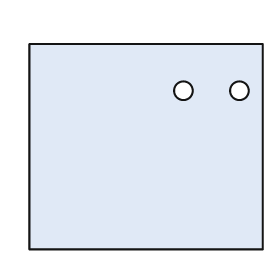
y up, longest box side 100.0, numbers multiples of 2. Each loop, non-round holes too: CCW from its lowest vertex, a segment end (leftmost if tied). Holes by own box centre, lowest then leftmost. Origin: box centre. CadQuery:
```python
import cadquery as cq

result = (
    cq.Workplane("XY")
    .moveTo(-50.0, -44.0)
    .lineTo(50.0, -44.0)
    .lineTo(50.0, 44.0)
    .lineTo(-50.0, 44.0)
    .close()
    .moveTo(16.0, 24.0)
    .circle(4.0)
    .moveTo(40.0, 24.0)
    .circle(4.0)
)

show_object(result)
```